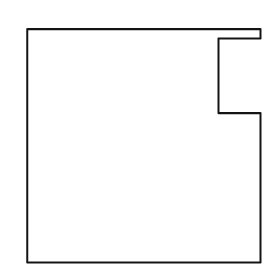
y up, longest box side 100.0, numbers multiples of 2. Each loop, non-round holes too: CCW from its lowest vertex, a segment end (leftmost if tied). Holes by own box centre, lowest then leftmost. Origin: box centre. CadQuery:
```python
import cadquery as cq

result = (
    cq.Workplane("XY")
    .moveTo(-50.0, -50.0)
    .lineTo(50.0, -50.0)
    .lineTo(50.0, 14.0)
    .lineTo(32.0, 14.0)
    .lineTo(32.0, 46.0)
    .lineTo(50.0, 46.0)
    .lineTo(50.0, 50.0)
    .lineTo(-50.0, 50.0)
    .close()
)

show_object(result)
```